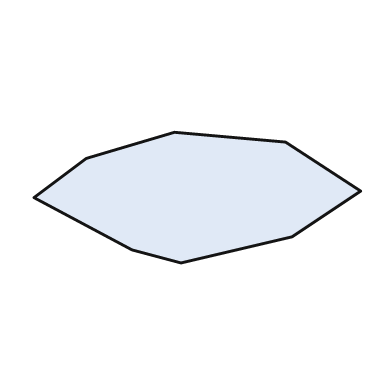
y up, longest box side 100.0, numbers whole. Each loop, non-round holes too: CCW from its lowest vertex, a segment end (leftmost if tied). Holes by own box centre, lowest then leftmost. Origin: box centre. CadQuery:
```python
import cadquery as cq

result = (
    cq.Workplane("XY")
    .moveTo(-5.0, -20.0)
    .lineTo(29.0, -12.0)
    .lineTo(50.0, 2.0)
    .lineTo(27.0, 17.0)
    .lineTo(-7.0, 20.0)
    .lineTo(-34.0, 12.0)
    .lineTo(-50.0, 0.0)
    .lineTo(-20.0, -16.0)
    .close()
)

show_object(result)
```